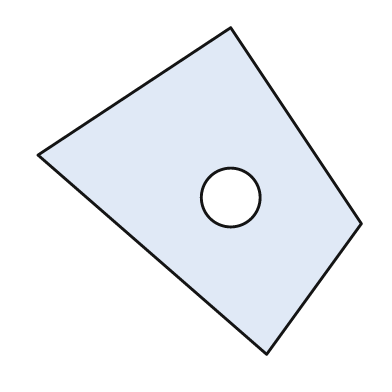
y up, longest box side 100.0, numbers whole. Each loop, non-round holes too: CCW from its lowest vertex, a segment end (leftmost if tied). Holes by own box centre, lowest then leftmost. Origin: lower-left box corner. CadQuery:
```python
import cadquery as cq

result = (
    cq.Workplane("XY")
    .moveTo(70.0, 0.0)
    .lineTo(99.0, 40.0)
    .lineTo(59.0, 100.0)
    .lineTo(0.0, 61.0)
    .close()
    .moveTo(59.0, 48.0)
    .circle(9.0)
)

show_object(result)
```